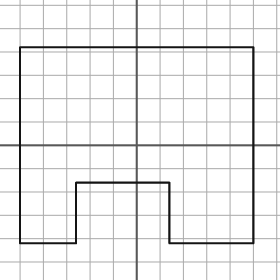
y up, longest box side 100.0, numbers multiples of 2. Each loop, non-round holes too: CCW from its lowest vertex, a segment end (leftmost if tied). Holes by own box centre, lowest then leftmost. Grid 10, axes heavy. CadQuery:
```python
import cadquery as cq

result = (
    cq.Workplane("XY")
    .moveTo(-50.0, -42.0)
    .lineTo(-26.0, -42.0)
    .lineTo(-26.0, -16.0)
    .lineTo(14.0, -16.0)
    .lineTo(14.0, -42.0)
    .lineTo(50.0, -42.0)
    .lineTo(50.0, 42.0)
    .lineTo(-50.0, 42.0)
    .close()
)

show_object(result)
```